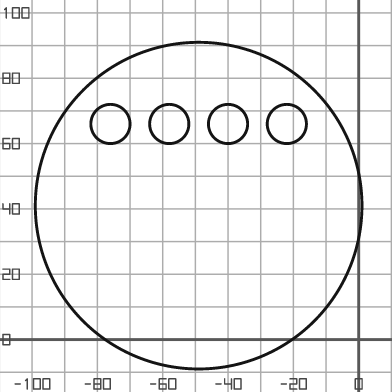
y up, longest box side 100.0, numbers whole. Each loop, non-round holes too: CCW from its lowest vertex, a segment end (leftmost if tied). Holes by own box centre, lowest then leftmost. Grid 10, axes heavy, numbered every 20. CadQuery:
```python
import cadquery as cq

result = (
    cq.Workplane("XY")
    .moveTo(-49.0, 41.0)
    .circle(50.0)
    .moveTo(-76.0, 66.0)
    .circle(6.0)
    .moveTo(-58.0, 66.0)
    .circle(6.0)
    .moveTo(-40.0, 66.0)
    .circle(6.0)
    .moveTo(-22.0, 66.0)
    .circle(6.0)
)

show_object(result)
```